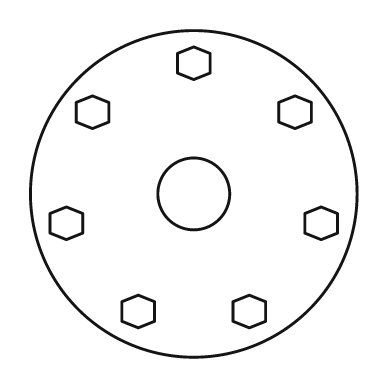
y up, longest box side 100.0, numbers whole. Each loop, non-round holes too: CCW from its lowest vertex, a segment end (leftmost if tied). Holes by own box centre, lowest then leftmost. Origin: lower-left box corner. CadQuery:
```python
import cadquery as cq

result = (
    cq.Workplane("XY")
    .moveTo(50.0, 50.0)
    .circle(50.0)
    .moveTo(33.0, 9.0)
    .lineTo(38.0, 11.0)
    .lineTo(38.0, 17.0)
    .lineTo(33.0, 19.0)
    .lineTo(28.0, 17.0)
    .lineTo(28.0, 11.0)
    .close()
    .moveTo(67.0, 9.0)
    .lineTo(72.0, 11.0)
    .lineTo(72.0, 17.0)
    .lineTo(67.0, 19.0)
    .lineTo(62.0, 17.0)
    .lineTo(62.0, 11.0)
    .close()
    .moveTo(11.0, 36.0)
    .lineTo(16.0, 38.0)
    .lineTo(16.0, 44.0)
    .lineTo(11.0, 46.0)
    .lineTo(6.0, 44.0)
    .lineTo(6.0, 38.0)
    .close()
    .moveTo(89.0, 36.0)
    .lineTo(94.0, 38.0)
    .lineTo(94.0, 44.0)
    .lineTo(89.0, 46.0)
    .lineTo(84.0, 44.0)
    .lineTo(84.0, 38.0)
    .close()
    .moveTo(50.0, 50.0)
    .circle(11.0)
    .moveTo(19.0, 70.0)
    .lineTo(24.0, 72.0)
    .lineTo(24.0, 78.0)
    .lineTo(19.0, 80.0)
    .lineTo(14.0, 78.0)
    .lineTo(14.0, 72.0)
    .close()
    .moveTo(81.0, 70.0)
    .lineTo(86.0, 72.0)
    .lineTo(86.0, 78.0)
    .lineTo(81.0, 80.0)
    .lineTo(76.0, 78.0)
    .lineTo(76.0, 72.0)
    .close()
    .moveTo(50.0, 85.0)
    .lineTo(55.0, 87.0)
    .lineTo(55.0, 93.0)
    .lineTo(50.0, 95.0)
    .lineTo(45.0, 93.0)
    .lineTo(45.0, 87.0)
    .close()
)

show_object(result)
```